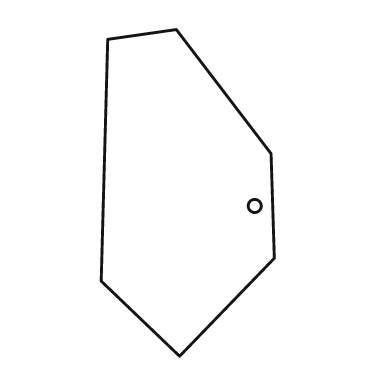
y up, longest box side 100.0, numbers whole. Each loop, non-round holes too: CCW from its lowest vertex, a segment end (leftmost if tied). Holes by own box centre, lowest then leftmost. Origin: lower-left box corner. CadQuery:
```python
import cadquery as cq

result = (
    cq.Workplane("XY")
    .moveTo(24.0, 0.0)
    .lineTo(53.0, 30.0)
    .lineTo(52.0, 62.0)
    .lineTo(23.0, 100.0)
    .lineTo(2.0, 97.0)
    .lineTo(0.0, 23.0)
    .close()
    .moveTo(47.0, 46.0)
    .circle(2.0)
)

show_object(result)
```